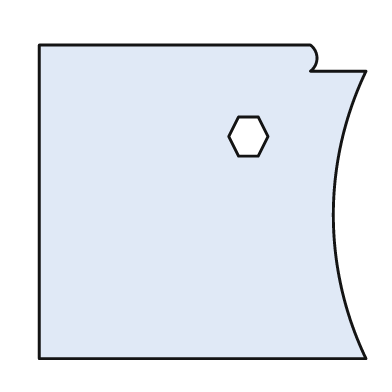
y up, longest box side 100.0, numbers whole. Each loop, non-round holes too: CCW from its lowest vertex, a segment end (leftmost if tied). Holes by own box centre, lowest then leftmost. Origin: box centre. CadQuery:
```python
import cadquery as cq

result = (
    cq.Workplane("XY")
    .moveTo(-50.0, -48.0)
    .lineTo(50.0, -48.0)
    .threePointArc((40.0, -4.0), (50.0, 40.0))
    .lineTo(33.0, 40.0)
    .threePointArc((35.0, 44.0), (33.0, 48.0))
    .lineTo(-50.0, 48.0)
    .close()
    .moveTo(11.0, 14.0)
    .lineTo(17.0, 14.0)
    .lineTo(20.0, 20.0)
    .lineTo(17.0, 26.0)
    .lineTo(11.0, 26.0)
    .lineTo(8.0, 20.0)
    .close()
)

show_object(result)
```